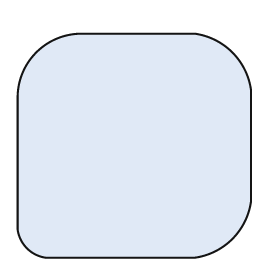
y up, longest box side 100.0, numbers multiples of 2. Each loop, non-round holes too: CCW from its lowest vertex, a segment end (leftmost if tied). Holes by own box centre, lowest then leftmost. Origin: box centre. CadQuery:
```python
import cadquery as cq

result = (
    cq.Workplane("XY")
    .moveTo(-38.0, -48.0)
    .lineTo(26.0, -48.0)
    .threePointArc((42.0, -40.0), (50.0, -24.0))
    .lineTo(50.0, 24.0)
    .threePointArc((42.0, 40.0), (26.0, 48.0))
    .lineTo(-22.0, 48.0)
    .threePointArc((-42.0, 40.0), (-50.0, 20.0))
    .lineTo(-50.0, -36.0)
    .threePointArc((-46.0, -44.0), (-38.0, -48.0))
    .close()
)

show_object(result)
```